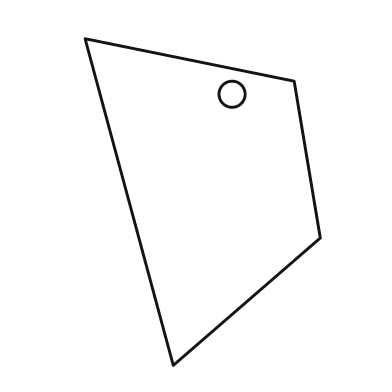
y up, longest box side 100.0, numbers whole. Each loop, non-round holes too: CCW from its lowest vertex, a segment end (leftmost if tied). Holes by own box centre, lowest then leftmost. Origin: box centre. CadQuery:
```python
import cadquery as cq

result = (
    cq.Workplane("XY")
    .moveTo(-9.0, -50.0)
    .lineTo(36.0, -11.0)
    .lineTo(28.0, 37.0)
    .lineTo(-36.0, 50.0)
    .close()
    .moveTo(9.0, 33.0)
    .circle(4.0)
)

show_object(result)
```